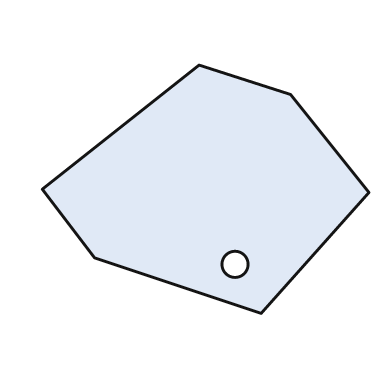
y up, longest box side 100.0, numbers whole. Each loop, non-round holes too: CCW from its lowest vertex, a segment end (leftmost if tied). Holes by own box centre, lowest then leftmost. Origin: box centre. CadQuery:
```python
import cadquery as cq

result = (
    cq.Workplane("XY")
    .moveTo(17.0, -38.0)
    .lineTo(50.0, -1.0)
    .lineTo(26.0, 29.0)
    .lineTo(-2.0, 38.0)
    .lineTo(-50.0, 0.0)
    .lineTo(-34.0, -21.0)
    .close()
    .moveTo(9.0, -23.0)
    .circle(4.0)
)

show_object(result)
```